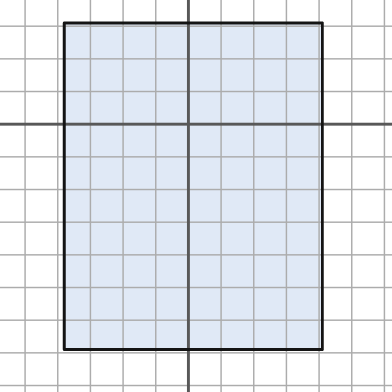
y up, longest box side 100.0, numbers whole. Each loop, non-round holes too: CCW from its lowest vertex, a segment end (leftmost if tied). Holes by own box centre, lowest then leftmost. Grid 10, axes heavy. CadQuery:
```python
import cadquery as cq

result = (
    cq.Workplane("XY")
    .moveTo(-38.0, -69.0)
    .lineTo(41.0, -69.0)
    .lineTo(41.0, 31.0)
    .lineTo(-38.0, 31.0)
    .close()
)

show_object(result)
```